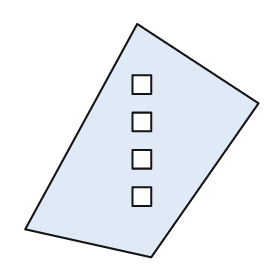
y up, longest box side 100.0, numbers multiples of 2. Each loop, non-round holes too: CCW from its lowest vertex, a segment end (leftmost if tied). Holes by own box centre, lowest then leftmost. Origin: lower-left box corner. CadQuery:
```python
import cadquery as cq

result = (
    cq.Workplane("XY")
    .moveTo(54.0, 0.0)
    .lineTo(100.0, 66.0)
    .lineTo(48.0, 100.0)
    .lineTo(0.0, 12.0)
    .close()
    .moveTo(46.0, 22.0)
    .lineTo(54.0, 22.0)
    .lineTo(54.0, 30.0)
    .lineTo(46.0, 30.0)
    .close()
    .moveTo(46.0, 38.0)
    .lineTo(54.0, 38.0)
    .lineTo(54.0, 46.0)
    .lineTo(46.0, 46.0)
    .close()
    .moveTo(46.0, 54.0)
    .lineTo(54.0, 54.0)
    .lineTo(54.0, 62.0)
    .lineTo(46.0, 62.0)
    .close()
    .moveTo(46.0, 70.0)
    .lineTo(54.0, 70.0)
    .lineTo(54.0, 78.0)
    .lineTo(46.0, 78.0)
    .close()
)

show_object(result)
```